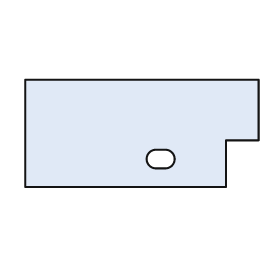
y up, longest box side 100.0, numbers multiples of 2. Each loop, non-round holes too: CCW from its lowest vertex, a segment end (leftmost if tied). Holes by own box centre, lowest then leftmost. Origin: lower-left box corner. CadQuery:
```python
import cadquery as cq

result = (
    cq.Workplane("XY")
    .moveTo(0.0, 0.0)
    .lineTo(86.0, 0.0)
    .lineTo(86.0, 20.0)
    .lineTo(100.0, 20.0)
    .lineTo(100.0, 46.0)
    .lineTo(0.0, 46.0)
    .close()
    .moveTo(56.0, 8.0)
    .lineTo(60.0, 8.0)
    .threePointArc((64.0, 12.0), (60.0, 16.0))
    .lineTo(56.0, 16.0)
    .threePointArc((52.0, 12.0), (56.0, 8.0))
    .close()
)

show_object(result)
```